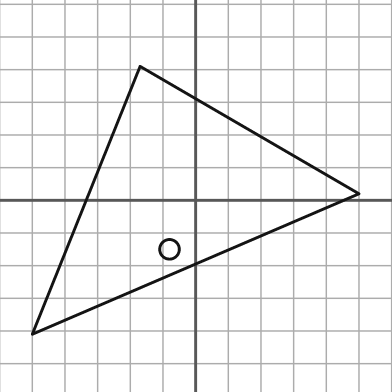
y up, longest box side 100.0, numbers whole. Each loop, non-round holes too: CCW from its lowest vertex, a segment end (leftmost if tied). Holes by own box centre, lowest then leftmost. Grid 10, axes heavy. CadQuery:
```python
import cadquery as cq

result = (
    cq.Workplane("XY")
    .moveTo(-50.0, -41.0)
    .lineTo(50.0, 2.0)
    .lineTo(-17.0, 41.0)
    .close()
    .moveTo(-8.0, -15.0)
    .circle(3.0)
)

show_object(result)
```